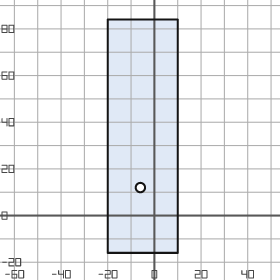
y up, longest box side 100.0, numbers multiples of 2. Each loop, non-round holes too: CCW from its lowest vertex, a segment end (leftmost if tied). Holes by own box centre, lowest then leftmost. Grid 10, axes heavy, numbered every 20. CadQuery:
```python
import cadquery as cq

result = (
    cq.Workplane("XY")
    .moveTo(-20.0, -16.0)
    .lineTo(10.0, -16.0)
    .lineTo(10.0, 84.0)
    .lineTo(-20.0, 84.0)
    .close()
    .moveTo(-6.0, 12.0)
    .circle(2.0)
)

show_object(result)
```